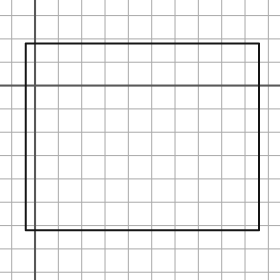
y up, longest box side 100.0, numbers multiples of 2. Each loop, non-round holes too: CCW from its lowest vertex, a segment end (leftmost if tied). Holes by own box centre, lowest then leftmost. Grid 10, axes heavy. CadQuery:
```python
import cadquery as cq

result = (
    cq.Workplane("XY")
    .moveTo(-4.0, -62.0)
    .lineTo(96.0, -62.0)
    .lineTo(96.0, 18.0)
    .lineTo(-4.0, 18.0)
    .close()
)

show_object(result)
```